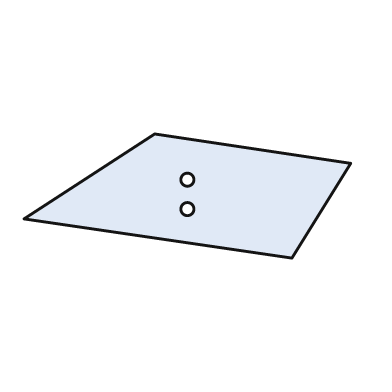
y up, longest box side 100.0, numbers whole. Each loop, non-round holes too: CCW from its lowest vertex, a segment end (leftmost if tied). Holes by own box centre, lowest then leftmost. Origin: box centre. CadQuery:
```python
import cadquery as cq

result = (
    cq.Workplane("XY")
    .moveTo(32.0, -19.0)
    .lineTo(50.0, 10.0)
    .lineTo(-10.0, 19.0)
    .lineTo(-50.0, -7.0)
    .close()
    .moveTo(0.0, -4.0)
    .circle(2.0)
    .moveTo(0.0, 5.0)
    .circle(2.0)
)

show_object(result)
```